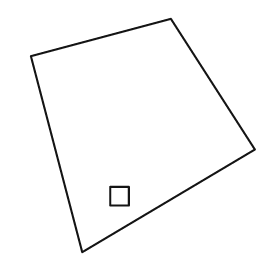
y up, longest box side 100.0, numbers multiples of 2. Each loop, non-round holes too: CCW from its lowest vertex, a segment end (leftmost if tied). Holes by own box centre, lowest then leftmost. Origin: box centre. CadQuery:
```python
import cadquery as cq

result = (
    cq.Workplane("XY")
    .moveTo(-26.0, -50.0)
    .lineTo(48.0, -6.0)
    .lineTo(12.0, 50.0)
    .lineTo(-48.0, 34.0)
    .close()
    .moveTo(-14.0, -30.0)
    .lineTo(-6.0, -30.0)
    .lineTo(-6.0, -22.0)
    .lineTo(-14.0, -22.0)
    .close()
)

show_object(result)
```